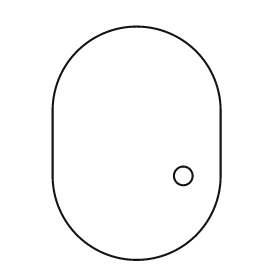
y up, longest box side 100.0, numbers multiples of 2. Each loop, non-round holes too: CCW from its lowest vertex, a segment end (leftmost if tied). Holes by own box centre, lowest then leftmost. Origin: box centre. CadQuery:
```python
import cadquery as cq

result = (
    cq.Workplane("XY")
    .moveTo(-36.0, -14.0)
    .threePointArc((0.0, -50.0), (36.0, -14.0))
    .lineTo(36.0, 14.0)
    .threePointArc((0.0, 50.0), (-36.0, 14.0))
    .close()
    .moveTo(20.0, -14.0)
    .circle(4.0)
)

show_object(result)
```